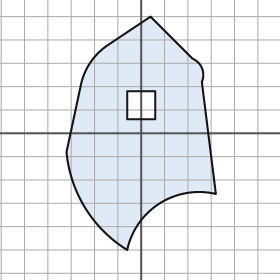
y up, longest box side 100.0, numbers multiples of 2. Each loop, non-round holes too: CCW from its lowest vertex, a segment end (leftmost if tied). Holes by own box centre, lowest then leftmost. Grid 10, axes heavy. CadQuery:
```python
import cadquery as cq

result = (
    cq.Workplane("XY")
    .moveTo(-6.0, -50.0)
    .threePointArc((8.0, -30.0), (32.0, -26.0))
    .lineTo(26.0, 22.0)
    .threePointArc((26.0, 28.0), (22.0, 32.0))
    .lineTo(4.0, 50.0)
    .lineTo(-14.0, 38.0)
    .threePointArc((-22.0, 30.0), (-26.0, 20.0))
    .lineTo(-32.0, -8.0)
    .threePointArc((-24.0, -32.0), (-6.0, -50.0))
    .close()
    .moveTo(-6.0, 6.0)
    .lineTo(6.0, 6.0)
    .lineTo(6.0, 18.0)
    .lineTo(-6.0, 18.0)
    .close()
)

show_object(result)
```